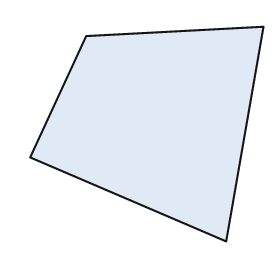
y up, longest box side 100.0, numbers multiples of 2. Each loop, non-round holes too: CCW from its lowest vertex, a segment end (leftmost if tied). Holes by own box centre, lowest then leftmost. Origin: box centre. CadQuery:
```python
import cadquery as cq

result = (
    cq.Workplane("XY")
    .moveTo(34.0, -46.0)
    .lineTo(50.0, 46.0)
    .lineTo(-26.0, 42.0)
    .lineTo(-50.0, -10.0)
    .close()
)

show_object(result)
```